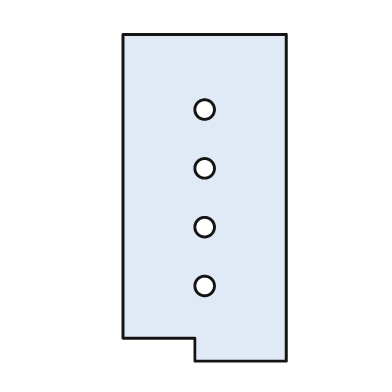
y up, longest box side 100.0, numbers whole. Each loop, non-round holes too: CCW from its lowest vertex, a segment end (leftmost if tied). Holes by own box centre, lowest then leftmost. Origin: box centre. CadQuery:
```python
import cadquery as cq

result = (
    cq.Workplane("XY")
    .moveTo(-3.0, -50.0)
    .lineTo(25.0, -50.0)
    .lineTo(25.0, 50.0)
    .lineTo(-25.0, 50.0)
    .lineTo(-25.0, -43.0)
    .lineTo(-3.0, -43.0)
    .close()
    .moveTo(0.0, -27.0)
    .circle(3.0)
    .moveTo(0.0, -9.0)
    .circle(3.0)
    .moveTo(0.0, 9.0)
    .circle(3.0)
    .moveTo(0.0, 27.0)
    .circle(3.0)
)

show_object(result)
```